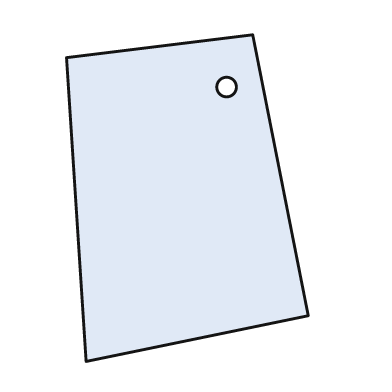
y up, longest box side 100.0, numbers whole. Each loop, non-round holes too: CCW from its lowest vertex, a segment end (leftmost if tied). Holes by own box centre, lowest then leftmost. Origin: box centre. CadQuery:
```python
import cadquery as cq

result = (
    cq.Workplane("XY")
    .moveTo(-31.0, -50.0)
    .lineTo(37.0, -36.0)
    .lineTo(20.0, 50.0)
    .lineTo(-37.0, 43.0)
    .close()
    .moveTo(12.0, 34.0)
    .circle(3.0)
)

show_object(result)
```